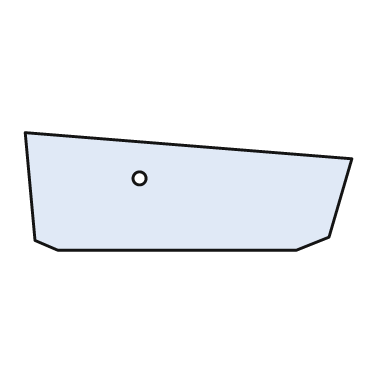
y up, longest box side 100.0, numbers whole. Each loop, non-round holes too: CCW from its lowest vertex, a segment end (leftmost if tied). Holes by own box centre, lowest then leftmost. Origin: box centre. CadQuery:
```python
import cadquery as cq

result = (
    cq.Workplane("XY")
    .moveTo(-40.0, -18.0)
    .lineTo(33.0, -18.0)
    .lineTo(43.0, -14.0)
    .lineTo(50.0, 10.0)
    .lineTo(-50.0, 18.0)
    .lineTo(-47.0, -15.0)
    .close()
    .moveTo(-15.0, 4.0)
    .circle(2.0)
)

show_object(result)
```